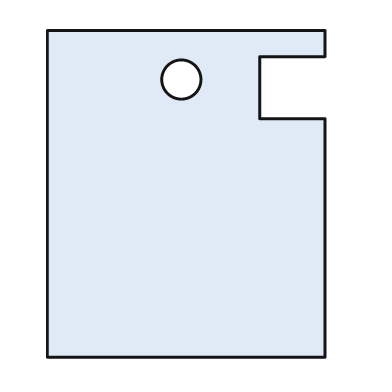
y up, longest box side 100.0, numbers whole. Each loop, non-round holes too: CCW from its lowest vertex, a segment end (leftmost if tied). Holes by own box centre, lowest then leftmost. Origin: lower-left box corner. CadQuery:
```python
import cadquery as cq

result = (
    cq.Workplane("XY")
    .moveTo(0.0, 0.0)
    .lineTo(85.0, 0.0)
    .lineTo(85.0, 73.0)
    .lineTo(65.0, 73.0)
    .lineTo(65.0, 92.0)
    .lineTo(85.0, 92.0)
    .lineTo(85.0, 100.0)
    .lineTo(0.0, 100.0)
    .close()
    .moveTo(41.0, 85.0)
    .circle(6.0)
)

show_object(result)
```